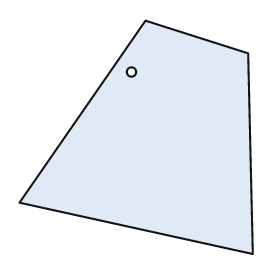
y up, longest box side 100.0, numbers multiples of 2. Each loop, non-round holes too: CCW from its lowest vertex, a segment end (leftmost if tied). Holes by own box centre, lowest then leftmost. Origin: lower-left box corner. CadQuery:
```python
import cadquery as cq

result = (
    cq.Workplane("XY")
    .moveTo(100.0, 0.0)
    .lineTo(98.0, 86.0)
    .lineTo(54.0, 100.0)
    .lineTo(0.0, 22.0)
    .close()
    .moveTo(48.0, 78.0)
    .circle(2.0)
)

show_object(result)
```